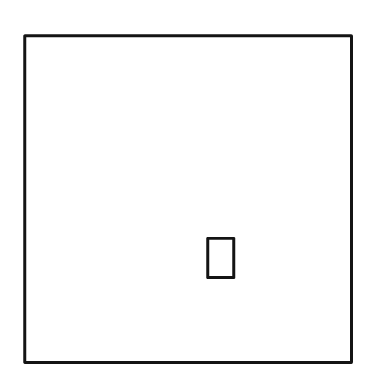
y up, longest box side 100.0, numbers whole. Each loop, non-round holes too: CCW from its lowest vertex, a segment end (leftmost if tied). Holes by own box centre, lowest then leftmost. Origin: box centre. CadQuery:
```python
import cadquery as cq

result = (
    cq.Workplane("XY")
    .moveTo(-50.0, -50.0)
    .lineTo(50.0, -50.0)
    .lineTo(50.0, 50.0)
    .lineTo(-50.0, 50.0)
    .close()
    .moveTo(6.0, -24.0)
    .lineTo(14.0, -24.0)
    .lineTo(14.0, -12.0)
    .lineTo(6.0, -12.0)
    .close()
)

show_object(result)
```